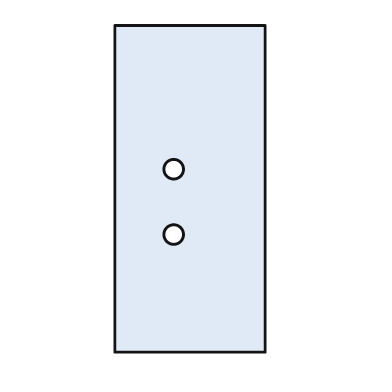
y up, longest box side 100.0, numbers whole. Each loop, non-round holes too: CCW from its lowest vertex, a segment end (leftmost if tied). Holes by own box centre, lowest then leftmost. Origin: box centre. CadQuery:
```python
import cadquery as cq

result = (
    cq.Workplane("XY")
    .moveTo(-23.0, -50.0)
    .lineTo(23.0, -50.0)
    .lineTo(23.0, 50.0)
    .lineTo(-23.0, 50.0)
    .close()
    .moveTo(-5.0, -14.0)
    .circle(3.0)
    .moveTo(-5.0, 6.0)
    .circle(3.0)
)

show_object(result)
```